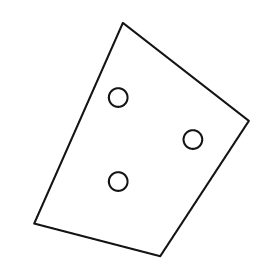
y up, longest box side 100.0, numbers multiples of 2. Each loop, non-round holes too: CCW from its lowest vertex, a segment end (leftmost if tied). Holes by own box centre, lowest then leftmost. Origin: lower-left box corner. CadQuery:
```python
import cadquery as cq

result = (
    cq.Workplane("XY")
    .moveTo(54.0, 0.0)
    .lineTo(92.0, 58.0)
    .lineTo(38.0, 100.0)
    .lineTo(0.0, 14.0)
    .close()
    .moveTo(36.0, 32.0)
    .circle(4.0)
    .moveTo(68.0, 50.0)
    .circle(4.0)
    .moveTo(36.0, 68.0)
    .circle(4.0)
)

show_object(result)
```